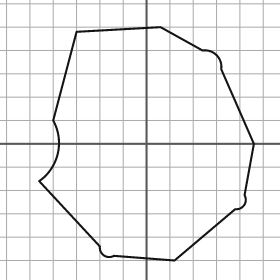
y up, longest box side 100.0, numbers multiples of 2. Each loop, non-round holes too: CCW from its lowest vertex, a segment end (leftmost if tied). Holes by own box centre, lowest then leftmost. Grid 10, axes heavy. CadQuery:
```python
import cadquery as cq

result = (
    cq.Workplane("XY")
    .moveTo(12.0, -50.0)
    .lineTo(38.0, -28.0)
    .threePointArc((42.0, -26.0), (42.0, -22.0))
    .lineTo(46.0, 0.0)
    .lineTo(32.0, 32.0)
    .threePointArc((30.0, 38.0), (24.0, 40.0))
    .lineTo(6.0, 50.0)
    .lineTo(-30.0, 48.0)
    .lineTo(-40.0, 10.0)
    .threePointArc((-38.0, -4.0), (-46.0, -16.0))
    .lineTo(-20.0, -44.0)
    .threePointArc((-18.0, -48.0), (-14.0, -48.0))
    .close()
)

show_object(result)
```